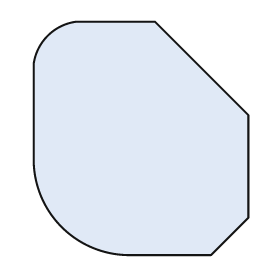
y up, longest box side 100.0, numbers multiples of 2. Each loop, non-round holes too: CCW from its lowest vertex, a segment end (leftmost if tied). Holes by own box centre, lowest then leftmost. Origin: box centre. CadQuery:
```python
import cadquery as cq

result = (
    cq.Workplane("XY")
    .moveTo(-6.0, -50.0)
    .lineTo(30.0, -50.0)
    .lineTo(46.0, -34.0)
    .lineTo(46.0, 10.0)
    .lineTo(6.0, 50.0)
    .lineTo(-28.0, 50.0)
    .threePointArc((-40.0, 44.0), (-46.0, 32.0))
    .lineTo(-46.0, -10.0)
    .threePointArc((-34.0, -38.0), (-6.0, -50.0))
    .close()
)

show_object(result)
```